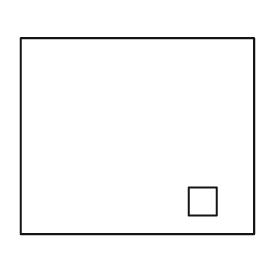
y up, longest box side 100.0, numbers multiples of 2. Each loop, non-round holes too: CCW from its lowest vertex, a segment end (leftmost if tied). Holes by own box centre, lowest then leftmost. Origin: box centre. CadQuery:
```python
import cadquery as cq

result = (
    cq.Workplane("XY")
    .moveTo(-50.0, -42.0)
    .lineTo(50.0, -42.0)
    .lineTo(50.0, 42.0)
    .lineTo(-50.0, 42.0)
    .close()
    .moveTo(22.0, -34.0)
    .lineTo(34.0, -34.0)
    .lineTo(34.0, -22.0)
    .lineTo(22.0, -22.0)
    .close()
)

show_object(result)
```